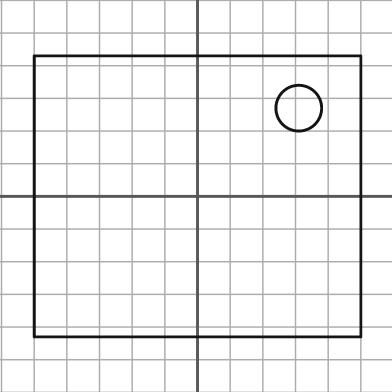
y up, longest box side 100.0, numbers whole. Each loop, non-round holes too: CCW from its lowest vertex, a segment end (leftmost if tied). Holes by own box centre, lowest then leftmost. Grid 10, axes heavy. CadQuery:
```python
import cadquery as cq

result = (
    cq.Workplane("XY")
    .moveTo(-50.0, -43.0)
    .lineTo(50.0, -43.0)
    .lineTo(50.0, 43.0)
    .lineTo(-50.0, 43.0)
    .close()
    .moveTo(31.0, 27.0)
    .circle(7.0)
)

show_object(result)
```